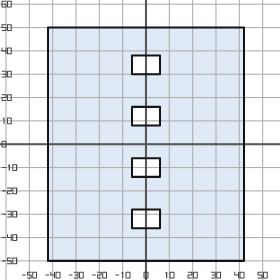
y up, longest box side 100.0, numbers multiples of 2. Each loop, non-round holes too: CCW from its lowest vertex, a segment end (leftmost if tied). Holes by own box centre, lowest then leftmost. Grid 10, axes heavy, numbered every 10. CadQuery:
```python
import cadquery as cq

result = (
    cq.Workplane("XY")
    .moveTo(-42.0, -50.0)
    .lineTo(42.0, -50.0)
    .lineTo(42.0, 50.0)
    .lineTo(-42.0, 50.0)
    .close()
    .moveTo(-6.0, -36.0)
    .lineTo(6.0, -36.0)
    .lineTo(6.0, -28.0)
    .lineTo(-6.0, -28.0)
    .close()
    .moveTo(-6.0, -14.0)
    .lineTo(6.0, -14.0)
    .lineTo(6.0, -6.0)
    .lineTo(-6.0, -6.0)
    .close()
    .moveTo(-6.0, 8.0)
    .lineTo(6.0, 8.0)
    .lineTo(6.0, 16.0)
    .lineTo(-6.0, 16.0)
    .close()
    .moveTo(-6.0, 30.0)
    .lineTo(6.0, 30.0)
    .lineTo(6.0, 38.0)
    .lineTo(-6.0, 38.0)
    .close()
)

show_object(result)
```